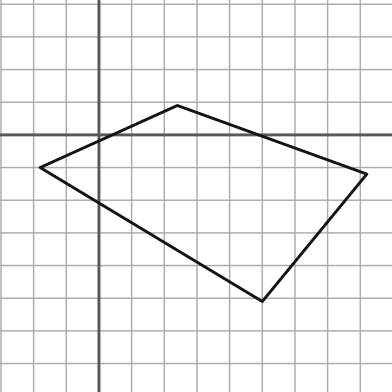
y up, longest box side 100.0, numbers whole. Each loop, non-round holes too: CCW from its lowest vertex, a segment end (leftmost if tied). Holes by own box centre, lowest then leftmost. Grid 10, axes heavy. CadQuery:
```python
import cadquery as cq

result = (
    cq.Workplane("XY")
    .moveTo(50.0, -51.0)
    .lineTo(82.0, -12.0)
    .lineTo(24.0, 9.0)
    .lineTo(-18.0, -10.0)
    .close()
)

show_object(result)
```